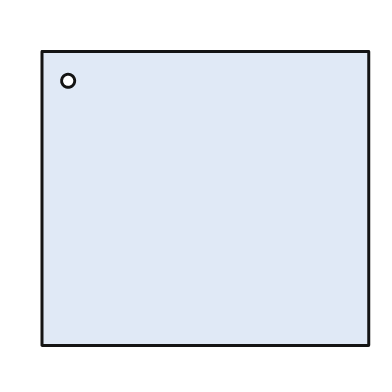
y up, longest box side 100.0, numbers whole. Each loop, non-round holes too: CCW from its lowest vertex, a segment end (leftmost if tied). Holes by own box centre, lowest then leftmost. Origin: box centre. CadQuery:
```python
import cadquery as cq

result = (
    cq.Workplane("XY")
    .moveTo(-50.0, -45.0)
    .lineTo(50.0, -45.0)
    .lineTo(50.0, 45.0)
    .lineTo(-50.0, 45.0)
    .close()
    .moveTo(-42.0, 36.0)
    .circle(2.0)
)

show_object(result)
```